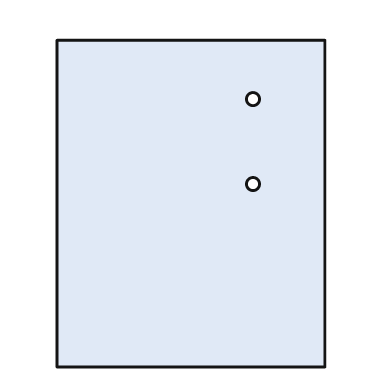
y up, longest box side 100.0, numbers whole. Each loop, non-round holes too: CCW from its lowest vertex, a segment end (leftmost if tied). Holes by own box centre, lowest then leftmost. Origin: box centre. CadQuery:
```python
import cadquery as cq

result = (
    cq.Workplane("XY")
    .moveTo(-41.0, -50.0)
    .lineTo(41.0, -50.0)
    .lineTo(41.0, 50.0)
    .lineTo(-41.0, 50.0)
    .close()
    .moveTo(19.0, 6.0)
    .circle(2.0)
    .moveTo(19.0, 32.0)
    .circle(2.0)
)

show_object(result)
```